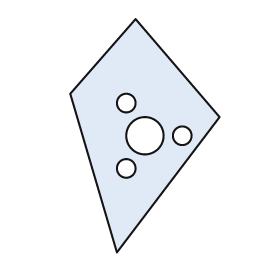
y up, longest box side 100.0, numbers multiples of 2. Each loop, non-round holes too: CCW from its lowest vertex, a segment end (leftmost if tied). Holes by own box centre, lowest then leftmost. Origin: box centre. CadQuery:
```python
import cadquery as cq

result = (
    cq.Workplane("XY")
    .moveTo(-12.0, -50.0)
    .lineTo(32.0, 8.0)
    .lineTo(-4.0, 50.0)
    .lineTo(-32.0, 18.0)
    .close()
    .moveTo(-8.0, -14.0)
    .circle(4.0)
    .moveTo(0.0, 0.0)
    .circle(8.0)
    .moveTo(16.0, 0.0)
    .circle(4.0)
    .moveTo(-8.0, 14.0)
    .circle(4.0)
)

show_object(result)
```